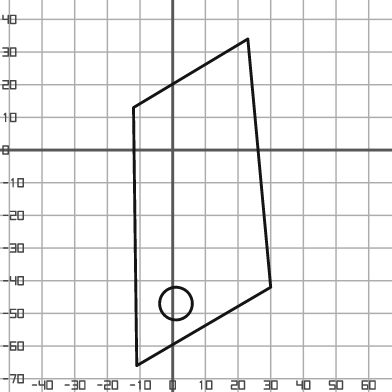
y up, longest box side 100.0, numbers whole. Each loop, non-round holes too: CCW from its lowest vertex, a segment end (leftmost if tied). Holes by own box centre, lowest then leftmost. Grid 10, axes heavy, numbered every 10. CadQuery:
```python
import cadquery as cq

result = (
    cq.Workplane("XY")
    .moveTo(-11.0, -66.0)
    .lineTo(30.0, -42.0)
    .lineTo(23.0, 34.0)
    .lineTo(-12.0, 13.0)
    .close()
    .moveTo(1.0, -47.0)
    .circle(5.0)
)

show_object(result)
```